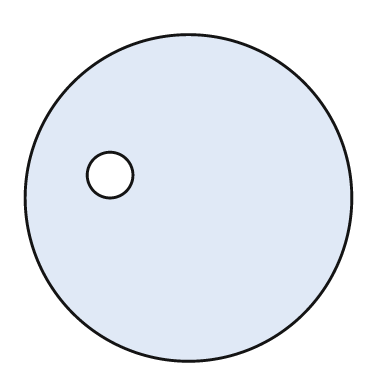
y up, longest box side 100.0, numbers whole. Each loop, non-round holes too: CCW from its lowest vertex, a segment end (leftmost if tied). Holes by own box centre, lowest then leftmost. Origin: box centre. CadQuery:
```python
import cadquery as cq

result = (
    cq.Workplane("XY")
    .moveTo(0.0, 0.0)
    .circle(50.0)
    .moveTo(-24.0, 7.0)
    .circle(7.0)
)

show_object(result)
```